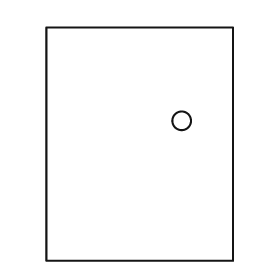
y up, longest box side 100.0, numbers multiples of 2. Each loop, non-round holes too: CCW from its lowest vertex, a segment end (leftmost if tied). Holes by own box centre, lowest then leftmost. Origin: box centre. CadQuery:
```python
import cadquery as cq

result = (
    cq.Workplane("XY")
    .moveTo(-40.0, -50.0)
    .lineTo(40.0, -50.0)
    .lineTo(40.0, 50.0)
    .lineTo(-40.0, 50.0)
    .close()
    .moveTo(18.0, 10.0)
    .circle(4.0)
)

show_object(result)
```